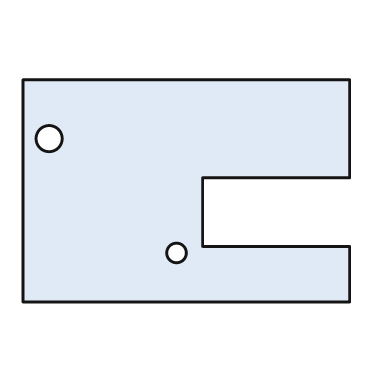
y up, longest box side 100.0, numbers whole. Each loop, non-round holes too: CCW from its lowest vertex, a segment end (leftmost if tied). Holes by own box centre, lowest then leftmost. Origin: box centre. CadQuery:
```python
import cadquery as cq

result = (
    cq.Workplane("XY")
    .moveTo(-50.0, -34.0)
    .lineTo(50.0, -34.0)
    .lineTo(50.0, -17.0)
    .lineTo(5.0, -17.0)
    .lineTo(5.0, 4.0)
    .lineTo(50.0, 4.0)
    .lineTo(50.0, 34.0)
    .lineTo(-50.0, 34.0)
    .close()
    .moveTo(-3.0, -19.0)
    .circle(3.0)
    .moveTo(-42.0, 16.0)
    .circle(4.0)
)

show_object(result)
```